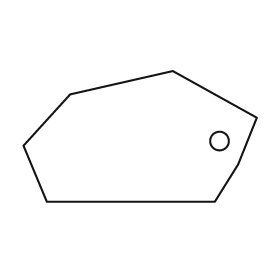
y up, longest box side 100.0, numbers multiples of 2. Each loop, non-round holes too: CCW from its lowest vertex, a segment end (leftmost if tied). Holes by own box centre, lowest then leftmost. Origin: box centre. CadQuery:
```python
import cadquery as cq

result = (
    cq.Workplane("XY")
    .moveTo(-40.0, -28.0)
    .lineTo(32.0, -28.0)
    .lineTo(42.0, -12.0)
    .lineTo(50.0, 8.0)
    .lineTo(14.0, 28.0)
    .lineTo(-30.0, 18.0)
    .lineTo(-50.0, -4.0)
    .close()
    .moveTo(34.0, -2.0)
    .circle(4.0)
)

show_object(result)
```